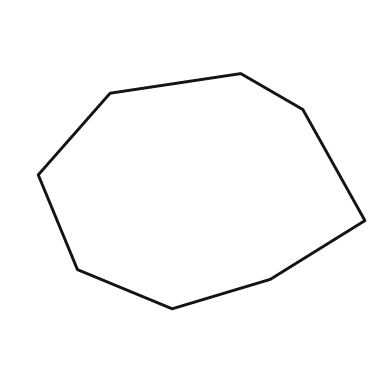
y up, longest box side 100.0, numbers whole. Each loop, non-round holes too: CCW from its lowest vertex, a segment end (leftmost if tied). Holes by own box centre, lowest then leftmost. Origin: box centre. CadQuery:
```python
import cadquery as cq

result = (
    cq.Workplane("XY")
    .moveTo(-9.0, -36.0)
    .lineTo(21.0, -27.0)
    .lineTo(50.0, -9.0)
    .lineTo(31.0, 25.0)
    .lineTo(12.0, 36.0)
    .lineTo(-28.0, 30.0)
    .lineTo(-50.0, 5.0)
    .lineTo(-38.0, -24.0)
    .close()
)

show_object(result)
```